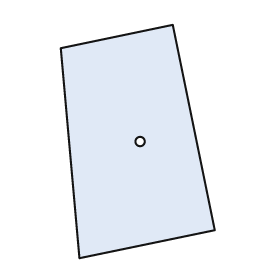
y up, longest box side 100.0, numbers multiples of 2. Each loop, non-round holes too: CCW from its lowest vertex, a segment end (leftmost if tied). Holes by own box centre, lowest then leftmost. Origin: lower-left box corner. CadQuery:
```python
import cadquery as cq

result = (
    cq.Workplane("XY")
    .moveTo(8.0, 0.0)
    .lineTo(66.0, 12.0)
    .lineTo(48.0, 100.0)
    .lineTo(0.0, 90.0)
    .close()
    .moveTo(34.0, 50.0)
    .circle(2.0)
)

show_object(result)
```